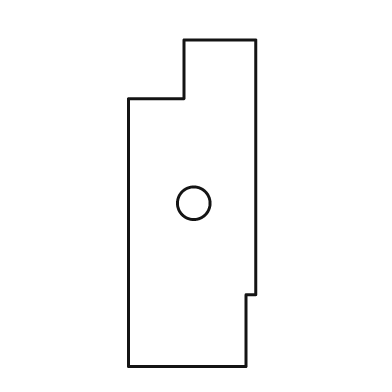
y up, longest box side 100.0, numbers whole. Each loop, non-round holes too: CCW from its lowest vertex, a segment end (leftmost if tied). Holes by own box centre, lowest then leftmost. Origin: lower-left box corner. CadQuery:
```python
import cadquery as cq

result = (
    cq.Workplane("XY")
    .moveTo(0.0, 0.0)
    .lineTo(36.0, 0.0)
    .lineTo(36.0, 22.0)
    .lineTo(39.0, 22.0)
    .lineTo(39.0, 100.0)
    .lineTo(17.0, 100.0)
    .lineTo(17.0, 82.0)
    .lineTo(0.0, 82.0)
    .close()
    .moveTo(20.0, 50.0)
    .circle(5.0)
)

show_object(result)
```